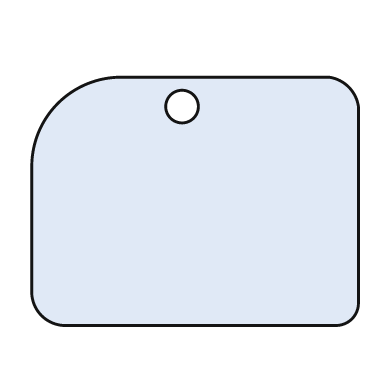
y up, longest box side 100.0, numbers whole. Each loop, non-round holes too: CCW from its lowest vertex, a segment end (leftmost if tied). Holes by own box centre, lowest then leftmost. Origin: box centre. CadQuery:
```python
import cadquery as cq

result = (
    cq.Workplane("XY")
    .moveTo(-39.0, -38.0)
    .lineTo(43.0, -38.0)
    .threePointArc((48.0, -36.0), (50.0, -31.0))
    .lineTo(50.0, 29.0)
    .threePointArc((47.0, 35.0), (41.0, 38.0))
    .lineTo(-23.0, 38.0)
    .threePointArc((-42.0, 30.0), (-50.0, 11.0))
    .lineTo(-50.0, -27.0)
    .threePointArc((-47.0, -35.0), (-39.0, -38.0))
    .close()
    .moveTo(-4.0, 29.0)
    .circle(5.0)
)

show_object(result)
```